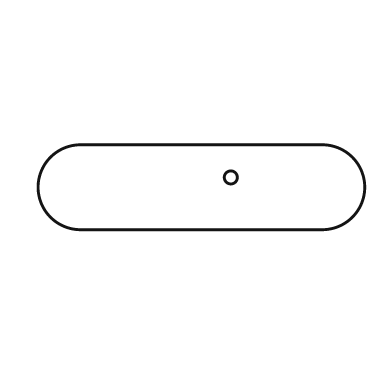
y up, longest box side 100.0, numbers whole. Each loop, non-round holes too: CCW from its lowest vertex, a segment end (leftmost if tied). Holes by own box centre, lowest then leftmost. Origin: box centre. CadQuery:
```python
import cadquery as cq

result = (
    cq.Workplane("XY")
    .moveTo(-37.0, -13.0)
    .lineTo(37.0, -13.0)
    .threePointArc((50.0, 0.0), (37.0, 13.0))
    .lineTo(-37.0, 13.0)
    .threePointArc((-50.0, 0.0), (-37.0, -13.0))
    .close()
    .moveTo(9.0, 3.0)
    .circle(2.0)
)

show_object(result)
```